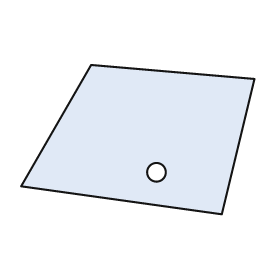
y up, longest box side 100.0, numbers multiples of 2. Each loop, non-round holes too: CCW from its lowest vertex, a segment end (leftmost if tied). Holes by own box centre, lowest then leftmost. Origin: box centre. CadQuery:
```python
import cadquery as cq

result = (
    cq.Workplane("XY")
    .moveTo(36.0, -32.0)
    .lineTo(50.0, 26.0)
    .lineTo(-20.0, 32.0)
    .lineTo(-50.0, -20.0)
    .close()
    .moveTo(8.0, -14.0)
    .circle(4.0)
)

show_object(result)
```